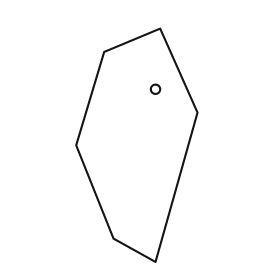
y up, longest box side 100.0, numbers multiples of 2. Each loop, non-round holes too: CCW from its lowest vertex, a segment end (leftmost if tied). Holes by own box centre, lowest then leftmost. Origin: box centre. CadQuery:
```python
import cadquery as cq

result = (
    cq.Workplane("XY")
    .moveTo(8.0, -50.0)
    .lineTo(26.0, 14.0)
    .lineTo(10.0, 50.0)
    .lineTo(-14.0, 40.0)
    .lineTo(-26.0, 0.0)
    .lineTo(-10.0, -40.0)
    .close()
    .moveTo(8.0, 24.0)
    .circle(2.0)
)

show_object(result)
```